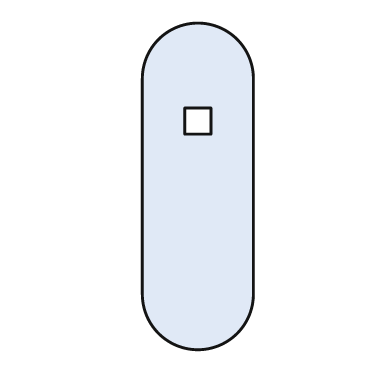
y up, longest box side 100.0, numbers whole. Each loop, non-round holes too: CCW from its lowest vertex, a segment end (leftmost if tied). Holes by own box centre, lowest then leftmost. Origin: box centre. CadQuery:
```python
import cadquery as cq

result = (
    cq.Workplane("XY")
    .moveTo(-17.0, -33.0)
    .threePointArc((0.0, -50.0), (17.0, -33.0))
    .lineTo(17.0, 33.0)
    .threePointArc((0.0, 50.0), (-17.0, 33.0))
    .close()
    .moveTo(-4.0, 16.0)
    .lineTo(4.0, 16.0)
    .lineTo(4.0, 24.0)
    .lineTo(-4.0, 24.0)
    .close()
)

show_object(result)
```